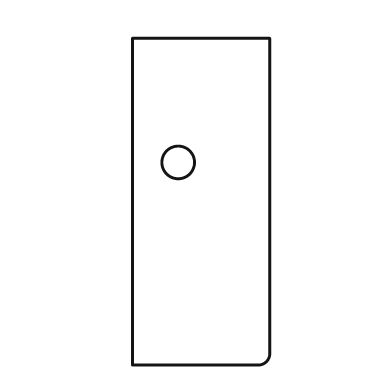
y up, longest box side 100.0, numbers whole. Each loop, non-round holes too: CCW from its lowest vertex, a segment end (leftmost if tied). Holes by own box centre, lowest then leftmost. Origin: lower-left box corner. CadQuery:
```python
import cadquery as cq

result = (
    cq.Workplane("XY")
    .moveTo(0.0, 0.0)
    .lineTo(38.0, 0.0)
    .threePointArc((41.0, 1.0), (42.0, 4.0))
    .lineTo(42.0, 100.0)
    .lineTo(0.0, 100.0)
    .close()
    .moveTo(14.0, 62.0)
    .circle(5.0)
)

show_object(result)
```